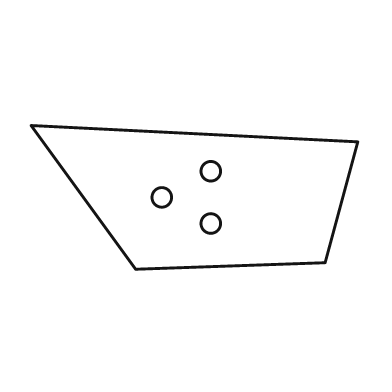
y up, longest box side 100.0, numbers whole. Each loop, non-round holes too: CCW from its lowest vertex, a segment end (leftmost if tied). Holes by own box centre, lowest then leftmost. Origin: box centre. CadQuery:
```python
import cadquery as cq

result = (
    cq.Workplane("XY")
    .moveTo(-18.0, -22.0)
    .lineTo(40.0, -20.0)
    .lineTo(50.0, 17.0)
    .lineTo(-50.0, 22.0)
    .close()
    .moveTo(5.0, -8.0)
    .circle(3.0)
    .moveTo(-10.0, 0.0)
    .circle(3.0)
    .moveTo(5.0, 8.0)
    .circle(3.0)
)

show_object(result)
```